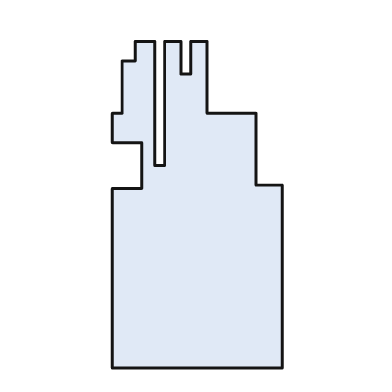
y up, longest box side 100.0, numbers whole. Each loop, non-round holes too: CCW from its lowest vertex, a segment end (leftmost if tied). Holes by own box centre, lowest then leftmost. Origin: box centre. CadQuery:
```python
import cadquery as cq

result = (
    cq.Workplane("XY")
    .moveTo(-26.0, -50.0)
    .lineTo(26.0, -50.0)
    .lineTo(26.0, 6.0)
    .lineTo(18.0, 6.0)
    .lineTo(18.0, 28.0)
    .lineTo(3.0, 28.0)
    .lineTo(3.0, 50.0)
    .lineTo(-2.0, 50.0)
    .lineTo(-2.0, 40.0)
    .lineTo(-5.0, 40.0)
    .lineTo(-5.0, 50.0)
    .lineTo(-10.0, 50.0)
    .lineTo(-10.0, 12.0)
    .lineTo(-13.0, 12.0)
    .lineTo(-13.0, 50.0)
    .lineTo(-19.0, 50.0)
    .lineTo(-19.0, 44.0)
    .lineTo(-23.0, 44.0)
    .lineTo(-23.0, 28.0)
    .lineTo(-26.0, 28.0)
    .lineTo(-26.0, 19.0)
    .lineTo(-17.0, 19.0)
    .lineTo(-17.0, 5.0)
    .lineTo(-26.0, 5.0)
    .close()
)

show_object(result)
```